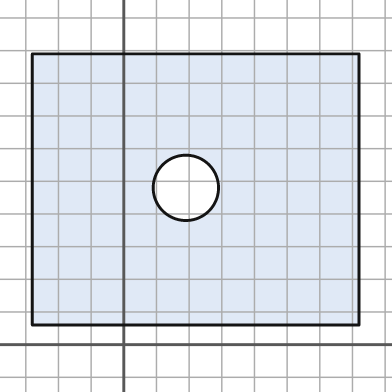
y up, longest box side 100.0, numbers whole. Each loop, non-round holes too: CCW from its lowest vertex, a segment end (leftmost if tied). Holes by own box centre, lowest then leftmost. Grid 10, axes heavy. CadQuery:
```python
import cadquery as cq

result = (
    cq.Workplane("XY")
    .moveTo(-28.0, 6.0)
    .lineTo(72.0, 6.0)
    .lineTo(72.0, 89.0)
    .lineTo(-28.0, 89.0)
    .close()
    .moveTo(19.0, 48.0)
    .circle(10.0)
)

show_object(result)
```